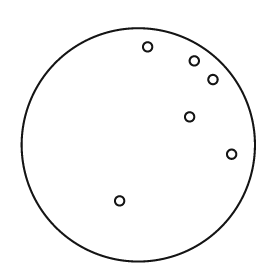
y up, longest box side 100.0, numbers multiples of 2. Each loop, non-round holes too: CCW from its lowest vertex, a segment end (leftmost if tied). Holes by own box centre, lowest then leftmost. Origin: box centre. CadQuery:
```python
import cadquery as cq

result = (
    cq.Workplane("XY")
    .moveTo(0.0, 0.0)
    .circle(50.0)
    .moveTo(-8.0, -24.0)
    .circle(2.0)
    .moveTo(40.0, -4.0)
    .circle(2.0)
    .moveTo(22.0, 12.0)
    .circle(2.0)
    .moveTo(32.0, 28.0)
    .circle(2.0)
    .moveTo(24.0, 36.0)
    .circle(2.0)
    .moveTo(4.0, 42.0)
    .circle(2.0)
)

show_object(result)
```